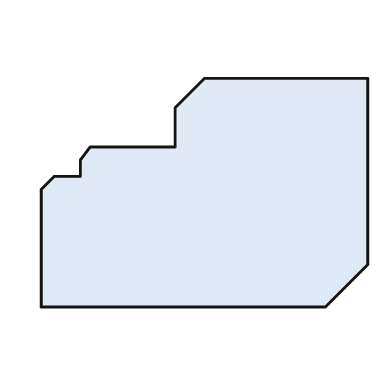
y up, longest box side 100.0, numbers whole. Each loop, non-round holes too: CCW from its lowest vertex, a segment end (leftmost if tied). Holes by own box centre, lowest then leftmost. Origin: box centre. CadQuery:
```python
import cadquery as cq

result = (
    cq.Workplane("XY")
    .moveTo(-50.0, -35.0)
    .lineTo(37.0, -35.0)
    .lineTo(50.0, -22.0)
    .lineTo(50.0, 35.0)
    .lineTo(0.0, 35.0)
    .lineTo(-9.0, 26.0)
    .lineTo(-9.0, 14.0)
    .lineTo(-35.0, 14.0)
    .lineTo(-38.0, 10.0)
    .lineTo(-38.0, 5.0)
    .lineTo(-46.0, 5.0)
    .lineTo(-50.0, 1.0)
    .close()
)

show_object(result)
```